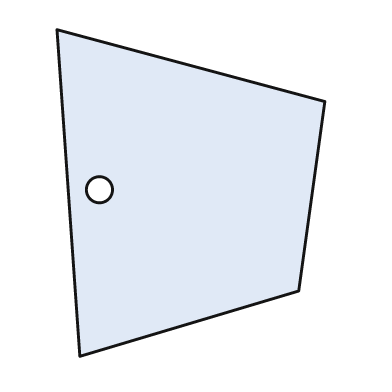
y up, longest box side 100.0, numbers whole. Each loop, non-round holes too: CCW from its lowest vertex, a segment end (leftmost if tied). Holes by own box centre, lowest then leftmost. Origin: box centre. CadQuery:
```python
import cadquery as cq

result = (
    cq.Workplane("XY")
    .moveTo(-34.0, -50.0)
    .lineTo(33.0, -30.0)
    .lineTo(41.0, 28.0)
    .lineTo(-41.0, 50.0)
    .close()
    .moveTo(-28.0, 1.0)
    .circle(4.0)
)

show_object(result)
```